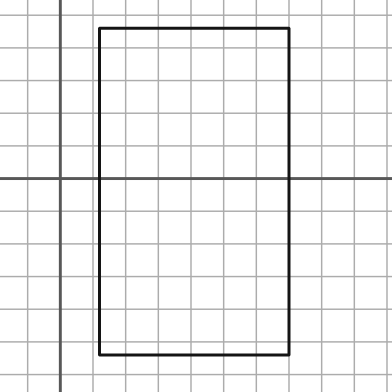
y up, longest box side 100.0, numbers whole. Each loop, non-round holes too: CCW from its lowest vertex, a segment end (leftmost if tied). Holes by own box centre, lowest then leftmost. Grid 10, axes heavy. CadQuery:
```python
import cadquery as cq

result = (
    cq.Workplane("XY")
    .moveTo(12.0, -54.0)
    .lineTo(70.0, -54.0)
    .lineTo(70.0, 46.0)
    .lineTo(12.0, 46.0)
    .close()
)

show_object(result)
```